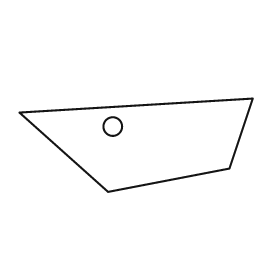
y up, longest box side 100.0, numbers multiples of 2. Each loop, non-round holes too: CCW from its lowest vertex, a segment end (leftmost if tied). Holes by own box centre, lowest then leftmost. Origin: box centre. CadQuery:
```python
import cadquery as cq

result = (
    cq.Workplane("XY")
    .moveTo(-12.0, -20.0)
    .lineTo(40.0, -10.0)
    .lineTo(50.0, 20.0)
    .lineTo(-50.0, 14.0)
    .close()
    .moveTo(-10.0, 8.0)
    .circle(4.0)
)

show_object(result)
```